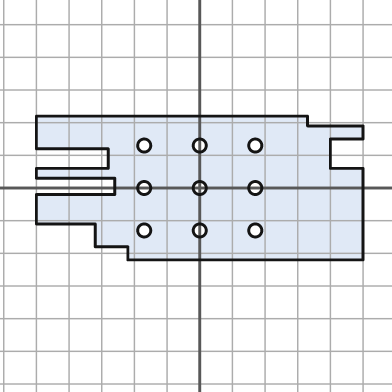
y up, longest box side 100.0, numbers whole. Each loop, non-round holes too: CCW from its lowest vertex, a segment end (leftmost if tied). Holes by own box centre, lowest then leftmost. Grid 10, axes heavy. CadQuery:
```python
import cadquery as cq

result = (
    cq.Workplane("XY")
    .moveTo(-22.0, -22.0)
    .lineTo(50.0, -22.0)
    .lineTo(50.0, 6.0)
    .lineTo(40.0, 6.0)
    .lineTo(40.0, 15.0)
    .lineTo(50.0, 15.0)
    .lineTo(50.0, 19.0)
    .lineTo(33.0, 19.0)
    .lineTo(33.0, 22.0)
    .lineTo(-50.0, 22.0)
    .lineTo(-50.0, 12.0)
    .lineTo(-28.0, 12.0)
    .lineTo(-28.0, 6.0)
    .lineTo(-50.0, 6.0)
    .lineTo(-50.0, 3.0)
    .lineTo(-26.0, 3.0)
    .lineTo(-26.0, -2.0)
    .lineTo(-50.0, -2.0)
    .lineTo(-50.0, -11.0)
    .lineTo(-32.0, -11.0)
    .lineTo(-32.0, -18.0)
    .lineTo(-22.0, -18.0)
    .close()
    .moveTo(-17.0, -13.0)
    .circle(2.0)
    .moveTo(0.0, -13.0)
    .circle(2.0)
    .moveTo(17.0, -13.0)
    .circle(2.0)
    .moveTo(-17.0, 0.0)
    .circle(2.0)
    .moveTo(0.0, 0.0)
    .circle(2.0)
    .moveTo(17.0, 0.0)
    .circle(2.0)
    .moveTo(-17.0, 13.0)
    .circle(2.0)
    .moveTo(0.0, 13.0)
    .circle(2.0)
    .moveTo(17.0, 13.0)
    .circle(2.0)
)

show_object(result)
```